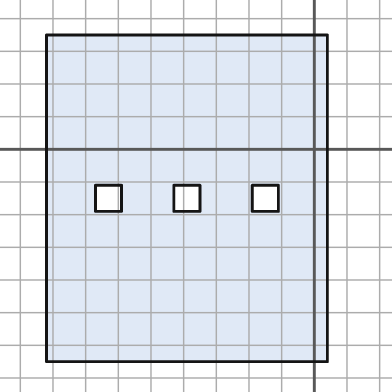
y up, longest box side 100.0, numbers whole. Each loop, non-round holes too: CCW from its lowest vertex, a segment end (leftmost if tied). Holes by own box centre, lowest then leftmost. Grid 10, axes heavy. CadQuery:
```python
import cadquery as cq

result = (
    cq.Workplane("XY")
    .moveTo(-82.0, -65.0)
    .lineTo(4.0, -65.0)
    .lineTo(4.0, 35.0)
    .lineTo(-82.0, 35.0)
    .close()
    .moveTo(-67.0, -19.0)
    .lineTo(-59.0, -19.0)
    .lineTo(-59.0, -11.0)
    .lineTo(-67.0, -11.0)
    .close()
    .moveTo(-43.0, -19.0)
    .lineTo(-35.0, -19.0)
    .lineTo(-35.0, -11.0)
    .lineTo(-43.0, -11.0)
    .close()
    .moveTo(-19.0, -19.0)
    .lineTo(-11.0, -19.0)
    .lineTo(-11.0, -11.0)
    .lineTo(-19.0, -11.0)
    .close()
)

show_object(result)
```